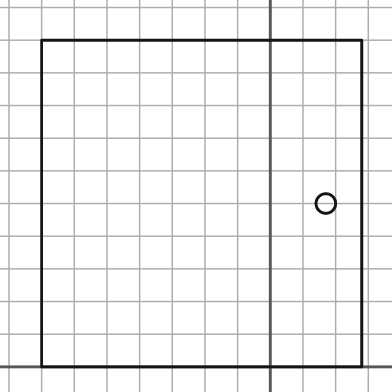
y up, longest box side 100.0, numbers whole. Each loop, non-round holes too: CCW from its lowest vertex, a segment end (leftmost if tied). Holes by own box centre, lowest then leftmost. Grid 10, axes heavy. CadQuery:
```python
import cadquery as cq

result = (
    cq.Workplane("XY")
    .moveTo(-70.0, 0.0)
    .lineTo(28.0, 0.0)
    .lineTo(28.0, 100.0)
    .lineTo(-70.0, 100.0)
    .close()
    .moveTo(17.0, 50.0)
    .circle(3.0)
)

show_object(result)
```